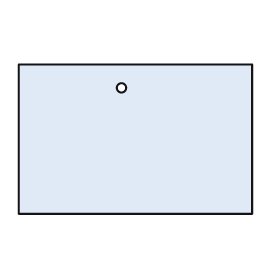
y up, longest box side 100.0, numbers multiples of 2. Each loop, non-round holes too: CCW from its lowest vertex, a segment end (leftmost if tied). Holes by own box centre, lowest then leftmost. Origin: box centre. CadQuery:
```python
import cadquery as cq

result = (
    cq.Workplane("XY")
    .moveTo(-50.0, -32.0)
    .lineTo(50.0, -32.0)
    .lineTo(50.0, 32.0)
    .lineTo(-50.0, 32.0)
    .close()
    .moveTo(-6.0, 22.0)
    .circle(2.0)
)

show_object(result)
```